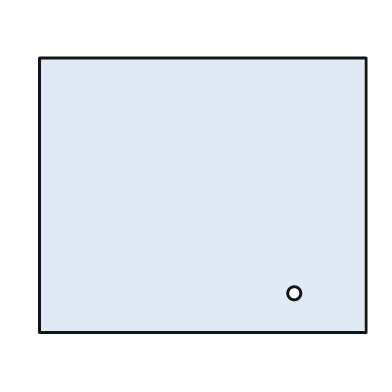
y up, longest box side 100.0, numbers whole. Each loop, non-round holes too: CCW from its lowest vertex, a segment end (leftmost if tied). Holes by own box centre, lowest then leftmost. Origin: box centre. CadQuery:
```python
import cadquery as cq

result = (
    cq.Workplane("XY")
    .moveTo(-50.0, -42.0)
    .lineTo(50.0, -42.0)
    .lineTo(50.0, 42.0)
    .lineTo(-50.0, 42.0)
    .close()
    .moveTo(28.0, -30.0)
    .circle(2.0)
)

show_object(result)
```